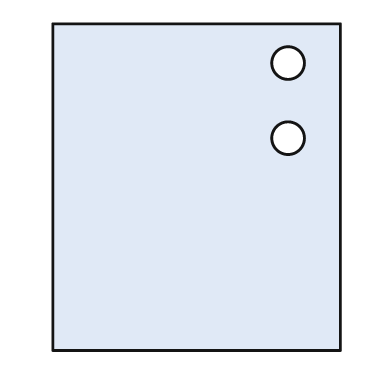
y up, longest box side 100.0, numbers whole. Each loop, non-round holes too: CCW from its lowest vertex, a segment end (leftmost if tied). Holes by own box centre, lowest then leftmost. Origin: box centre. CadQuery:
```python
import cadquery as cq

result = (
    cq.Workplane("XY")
    .moveTo(-44.0, -50.0)
    .lineTo(44.0, -50.0)
    .lineTo(44.0, 50.0)
    .lineTo(-44.0, 50.0)
    .close()
    .moveTo(28.0, 15.0)
    .circle(5.0)
    .moveTo(28.0, 38.0)
    .circle(5.0)
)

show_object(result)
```